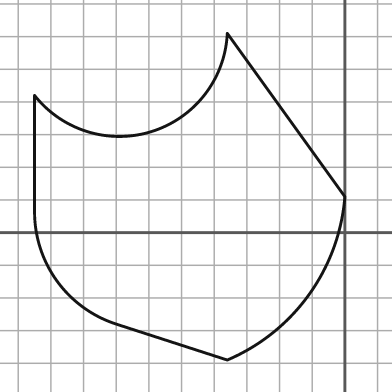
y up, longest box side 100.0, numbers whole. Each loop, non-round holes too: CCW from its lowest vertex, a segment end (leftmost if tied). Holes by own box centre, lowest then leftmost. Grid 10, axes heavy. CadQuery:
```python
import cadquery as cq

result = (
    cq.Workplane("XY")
    .moveTo(-36.0, -39.0)
    .threePointArc((-11.0, -19.0), (0.0, 11.0))
    .lineTo(-36.0, 61.0)
    .threePointArc((-59.0, 31.0), (-95.0, 42.0))
    .lineTo(-95.0, 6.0)
    .threePointArc((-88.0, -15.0), (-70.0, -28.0))
    .close()
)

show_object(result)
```